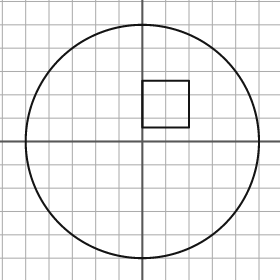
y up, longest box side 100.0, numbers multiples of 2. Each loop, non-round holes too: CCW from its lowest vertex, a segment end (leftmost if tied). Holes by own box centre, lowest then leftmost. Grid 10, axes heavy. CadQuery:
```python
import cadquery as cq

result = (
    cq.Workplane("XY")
    .moveTo(0.0, 0.0)
    .circle(50.0)
    .moveTo(0.0, 6.0)
    .lineTo(20.0, 6.0)
    .lineTo(20.0, 26.0)
    .lineTo(0.0, 26.0)
    .close()
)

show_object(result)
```